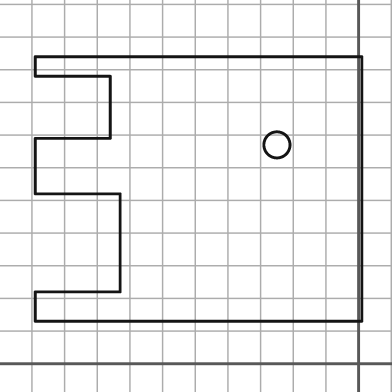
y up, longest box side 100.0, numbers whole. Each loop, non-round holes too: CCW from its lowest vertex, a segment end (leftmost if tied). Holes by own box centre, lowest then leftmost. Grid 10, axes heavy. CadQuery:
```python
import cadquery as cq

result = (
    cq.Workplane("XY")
    .moveTo(-99.0, 13.0)
    .lineTo(1.0, 13.0)
    .lineTo(1.0, 94.0)
    .lineTo(-99.0, 94.0)
    .lineTo(-99.0, 88.0)
    .lineTo(-76.0, 88.0)
    .lineTo(-76.0, 69.0)
    .lineTo(-99.0, 69.0)
    .lineTo(-99.0, 52.0)
    .lineTo(-73.0, 52.0)
    .lineTo(-73.0, 22.0)
    .lineTo(-99.0, 22.0)
    .close()
    .moveTo(-25.0, 67.0)
    .circle(4.0)
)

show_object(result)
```